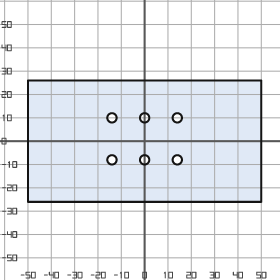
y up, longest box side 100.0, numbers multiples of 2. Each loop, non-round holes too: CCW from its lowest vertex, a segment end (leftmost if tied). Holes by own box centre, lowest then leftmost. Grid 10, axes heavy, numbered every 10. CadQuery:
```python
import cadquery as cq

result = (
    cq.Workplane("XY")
    .moveTo(-50.0, -26.0)
    .lineTo(50.0, -26.0)
    .lineTo(50.0, 26.0)
    .lineTo(-50.0, 26.0)
    .close()
    .moveTo(-14.0, -8.0)
    .circle(2.0)
    .moveTo(0.0, -8.0)
    .circle(2.0)
    .moveTo(14.0, -8.0)
    .circle(2.0)
    .moveTo(-14.0, 10.0)
    .circle(2.0)
    .moveTo(0.0, 10.0)
    .circle(2.0)
    .moveTo(14.0, 10.0)
    .circle(2.0)
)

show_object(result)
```